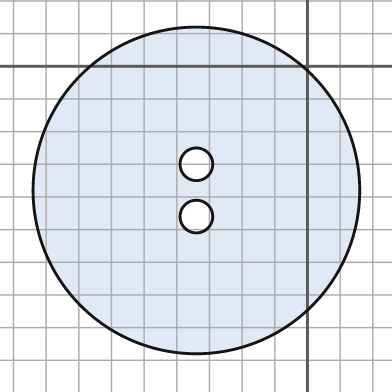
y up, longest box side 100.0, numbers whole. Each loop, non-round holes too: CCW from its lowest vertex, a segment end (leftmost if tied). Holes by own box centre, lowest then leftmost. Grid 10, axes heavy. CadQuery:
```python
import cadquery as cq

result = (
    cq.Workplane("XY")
    .moveTo(-34.0, -38.0)
    .circle(50.0)
    .moveTo(-34.0, -46.0)
    .circle(5.0)
    .moveTo(-34.0, -30.0)
    .circle(5.0)
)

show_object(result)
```